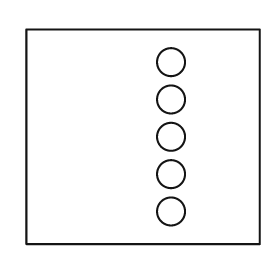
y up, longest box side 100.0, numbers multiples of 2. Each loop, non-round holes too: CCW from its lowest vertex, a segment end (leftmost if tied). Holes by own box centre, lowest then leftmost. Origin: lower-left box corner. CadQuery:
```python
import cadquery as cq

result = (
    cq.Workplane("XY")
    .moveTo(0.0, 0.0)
    .lineTo(100.0, 0.0)
    .lineTo(100.0, 92.0)
    .lineTo(0.0, 92.0)
    .close()
    .moveTo(62.0, 14.0)
    .circle(6.0)
    .moveTo(62.0, 30.0)
    .circle(6.0)
    .moveTo(62.0, 46.0)
    .circle(6.0)
    .moveTo(62.0, 62.0)
    .circle(6.0)
    .moveTo(62.0, 78.0)
    .circle(6.0)
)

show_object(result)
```